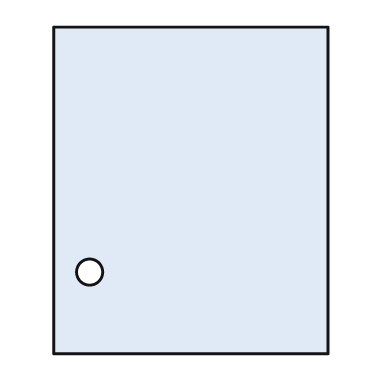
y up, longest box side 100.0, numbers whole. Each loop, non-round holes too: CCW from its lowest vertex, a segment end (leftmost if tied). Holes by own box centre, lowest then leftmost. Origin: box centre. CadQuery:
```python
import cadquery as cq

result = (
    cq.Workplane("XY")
    .moveTo(-42.0, -50.0)
    .lineTo(42.0, -50.0)
    .lineTo(42.0, 50.0)
    .lineTo(-42.0, 50.0)
    .close()
    .moveTo(-31.0, -25.0)
    .circle(4.0)
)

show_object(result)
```